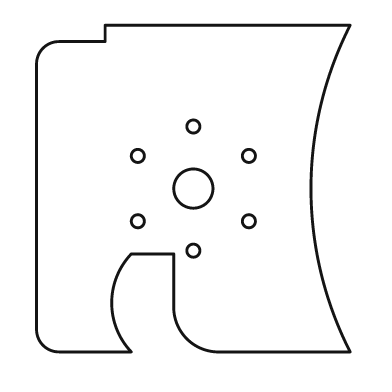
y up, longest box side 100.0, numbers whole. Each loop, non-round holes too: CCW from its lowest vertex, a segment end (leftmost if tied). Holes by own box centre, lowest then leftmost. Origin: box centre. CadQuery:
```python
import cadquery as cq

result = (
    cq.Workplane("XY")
    .moveTo(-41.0, -50.0)
    .lineTo(-19.0, -50.0)
    .threePointArc((-25.0, -35.0), (-19.0, -20.0))
    .lineTo(-6.0, -20.0)
    .lineTo(-6.0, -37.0)
    .threePointArc((-2.0, -46.0), (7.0, -50.0))
    .lineTo(48.0, -50.0)
    .threePointArc((36.0, 0.0), (48.0, 50.0))
    .lineTo(-27.0, 50.0)
    .lineTo(-27.0, 45.0)
    .lineTo(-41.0, 45.0)
    .threePointArc((-46.0, 43.0), (-48.0, 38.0))
    .lineTo(-48.0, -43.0)
    .threePointArc((-46.0, -48.0), (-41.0, -50.0))
    .close()
    .moveTo(0.0, -19.0)
    .circle(2.0)
    .moveTo(-17.0, -10.0)
    .circle(2.0)
    .moveTo(17.0, -10.0)
    .circle(2.0)
    .moveTo(0.0, 0.0)
    .circle(6.0)
    .moveTo(-17.0, 10.0)
    .circle(2.0)
    .moveTo(17.0, 10.0)
    .circle(2.0)
    .moveTo(0.0, 19.0)
    .circle(2.0)
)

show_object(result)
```